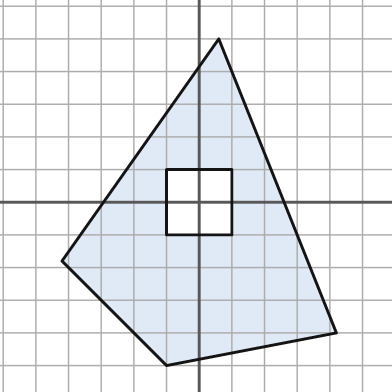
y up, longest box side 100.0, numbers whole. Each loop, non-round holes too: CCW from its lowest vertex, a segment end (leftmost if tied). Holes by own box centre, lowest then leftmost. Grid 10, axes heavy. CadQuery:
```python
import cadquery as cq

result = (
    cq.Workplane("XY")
    .moveTo(-10.0, -50.0)
    .lineTo(42.0, -40.0)
    .lineTo(6.0, 50.0)
    .lineTo(-42.0, -18.0)
    .close()
    .moveTo(-10.0, -10.0)
    .lineTo(10.0, -10.0)
    .lineTo(10.0, 10.0)
    .lineTo(-10.0, 10.0)
    .close()
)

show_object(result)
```